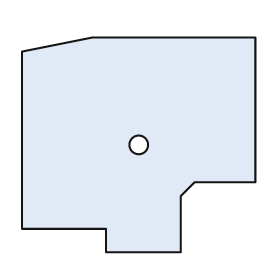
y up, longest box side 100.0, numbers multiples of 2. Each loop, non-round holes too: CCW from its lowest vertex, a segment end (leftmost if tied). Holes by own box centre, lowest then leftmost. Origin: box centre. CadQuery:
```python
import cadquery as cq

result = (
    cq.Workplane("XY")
    .moveTo(-14.0, -46.0)
    .lineTo(18.0, -46.0)
    .lineTo(18.0, -22.0)
    .lineTo(24.0, -16.0)
    .lineTo(50.0, -16.0)
    .lineTo(50.0, 46.0)
    .lineTo(-20.0, 46.0)
    .lineTo(-50.0, 40.0)
    .lineTo(-50.0, -36.0)
    .lineTo(-14.0, -36.0)
    .close()
    .moveTo(0.0, 0.0)
    .circle(4.0)
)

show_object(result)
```